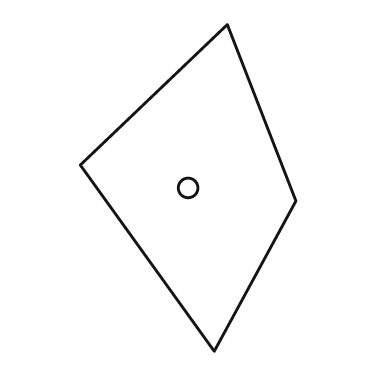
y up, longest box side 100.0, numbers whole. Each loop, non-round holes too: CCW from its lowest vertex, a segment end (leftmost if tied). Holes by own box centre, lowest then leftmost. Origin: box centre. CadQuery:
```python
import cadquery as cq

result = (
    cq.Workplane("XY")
    .moveTo(8.0, -50.0)
    .lineTo(33.0, -4.0)
    .lineTo(12.0, 50.0)
    .lineTo(-33.0, 7.0)
    .close()
    .moveTo(0.0, 0.0)
    .circle(3.0)
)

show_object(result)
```